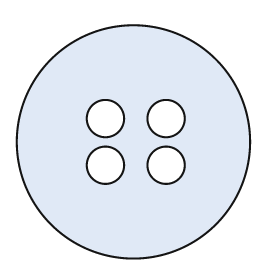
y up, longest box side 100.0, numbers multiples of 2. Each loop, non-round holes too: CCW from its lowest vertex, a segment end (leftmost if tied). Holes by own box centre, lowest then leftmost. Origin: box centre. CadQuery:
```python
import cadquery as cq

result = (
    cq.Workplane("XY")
    .moveTo(0.0, 0.0)
    .circle(50.0)
    .moveTo(-12.0, -10.0)
    .circle(8.0)
    .moveTo(14.0, -10.0)
    .circle(8.0)
    .moveTo(-12.0, 10.0)
    .circle(8.0)
    .moveTo(14.0, 10.0)
    .circle(8.0)
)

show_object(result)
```